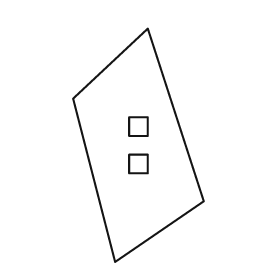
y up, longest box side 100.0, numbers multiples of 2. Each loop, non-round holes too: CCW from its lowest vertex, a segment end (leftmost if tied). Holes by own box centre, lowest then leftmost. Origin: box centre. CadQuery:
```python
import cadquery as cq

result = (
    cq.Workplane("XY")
    .moveTo(-10.0, -50.0)
    .lineTo(28.0, -24.0)
    .lineTo(4.0, 50.0)
    .lineTo(-28.0, 20.0)
    .close()
    .moveTo(-4.0, -12.0)
    .lineTo(4.0, -12.0)
    .lineTo(4.0, -4.0)
    .lineTo(-4.0, -4.0)
    .close()
    .moveTo(-4.0, 4.0)
    .lineTo(4.0, 4.0)
    .lineTo(4.0, 12.0)
    .lineTo(-4.0, 12.0)
    .close()
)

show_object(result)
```